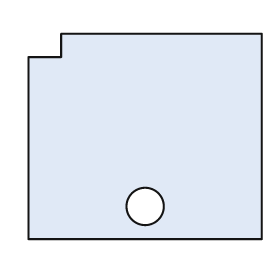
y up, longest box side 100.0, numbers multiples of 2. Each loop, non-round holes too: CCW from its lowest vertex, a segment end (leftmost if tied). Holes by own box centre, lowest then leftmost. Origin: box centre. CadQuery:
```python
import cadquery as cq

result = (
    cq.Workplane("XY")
    .moveTo(-50.0, -44.0)
    .lineTo(50.0, -44.0)
    .lineTo(50.0, 44.0)
    .lineTo(-36.0, 44.0)
    .lineTo(-36.0, 34.0)
    .lineTo(-50.0, 34.0)
    .close()
    .moveTo(0.0, -30.0)
    .circle(8.0)
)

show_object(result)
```